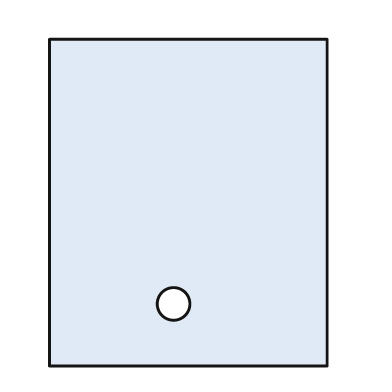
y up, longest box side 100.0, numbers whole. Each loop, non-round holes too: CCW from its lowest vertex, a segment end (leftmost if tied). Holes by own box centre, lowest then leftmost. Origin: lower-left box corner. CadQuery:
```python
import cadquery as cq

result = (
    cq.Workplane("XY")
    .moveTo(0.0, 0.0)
    .lineTo(85.0, 0.0)
    .lineTo(85.0, 100.0)
    .lineTo(0.0, 100.0)
    .close()
    .moveTo(38.0, 19.0)
    .circle(5.0)
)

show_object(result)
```